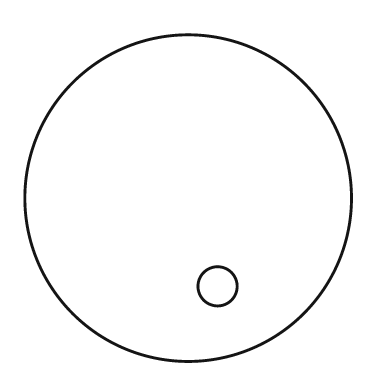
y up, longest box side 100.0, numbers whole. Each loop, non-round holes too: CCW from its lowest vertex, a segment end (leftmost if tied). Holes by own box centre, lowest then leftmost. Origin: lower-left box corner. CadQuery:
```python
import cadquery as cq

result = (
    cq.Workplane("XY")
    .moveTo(50.0, 50.0)
    .circle(50.0)
    .moveTo(59.0, 23.0)
    .circle(6.0)
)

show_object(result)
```